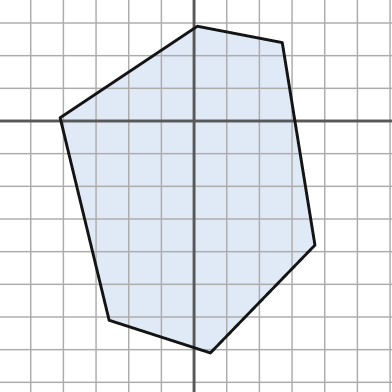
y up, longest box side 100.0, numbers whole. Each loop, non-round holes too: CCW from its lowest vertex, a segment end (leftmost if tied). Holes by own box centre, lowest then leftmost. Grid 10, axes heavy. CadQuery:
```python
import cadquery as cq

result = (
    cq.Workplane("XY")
    .moveTo(5.0, -71.0)
    .lineTo(37.0, -38.0)
    .lineTo(27.0, 24.0)
    .lineTo(1.0, 29.0)
    .lineTo(-41.0, 1.0)
    .lineTo(-26.0, -61.0)
    .close()
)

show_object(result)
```